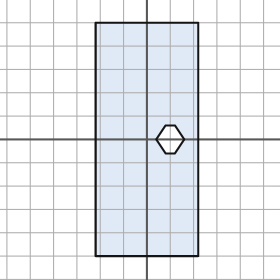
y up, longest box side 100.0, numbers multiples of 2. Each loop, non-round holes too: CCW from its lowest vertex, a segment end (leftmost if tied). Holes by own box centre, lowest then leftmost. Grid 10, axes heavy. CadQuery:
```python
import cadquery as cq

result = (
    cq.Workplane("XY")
    .moveTo(-22.0, -50.0)
    .lineTo(22.0, -50.0)
    .lineTo(22.0, 50.0)
    .lineTo(-22.0, 50.0)
    .close()
    .moveTo(8.0, -6.0)
    .lineTo(12.0, -6.0)
    .lineTo(16.0, 0.0)
    .lineTo(12.0, 6.0)
    .lineTo(8.0, 6.0)
    .lineTo(4.0, 0.0)
    .close()
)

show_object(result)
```